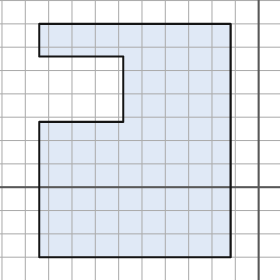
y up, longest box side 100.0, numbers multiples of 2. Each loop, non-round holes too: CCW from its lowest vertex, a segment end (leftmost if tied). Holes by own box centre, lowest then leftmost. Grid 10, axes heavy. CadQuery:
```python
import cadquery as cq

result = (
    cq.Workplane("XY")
    .moveTo(-94.0, -30.0)
    .lineTo(-12.0, -30.0)
    .lineTo(-12.0, 70.0)
    .lineTo(-94.0, 70.0)
    .lineTo(-94.0, 56.0)
    .lineTo(-58.0, 56.0)
    .lineTo(-58.0, 28.0)
    .lineTo(-94.0, 28.0)
    .close()
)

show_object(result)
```